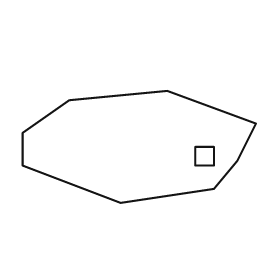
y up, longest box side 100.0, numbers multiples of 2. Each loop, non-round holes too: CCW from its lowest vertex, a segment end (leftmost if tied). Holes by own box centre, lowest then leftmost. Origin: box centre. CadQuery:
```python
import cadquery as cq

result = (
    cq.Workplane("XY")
    .moveTo(-8.0, -24.0)
    .lineTo(32.0, -18.0)
    .lineTo(42.0, -6.0)
    .lineTo(50.0, 10.0)
    .lineTo(12.0, 24.0)
    .lineTo(-30.0, 20.0)
    .lineTo(-50.0, 6.0)
    .lineTo(-50.0, -8.0)
    .close()
    .moveTo(24.0, -8.0)
    .lineTo(32.0, -8.0)
    .lineTo(32.0, 0.0)
    .lineTo(24.0, 0.0)
    .close()
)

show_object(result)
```